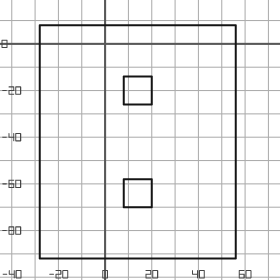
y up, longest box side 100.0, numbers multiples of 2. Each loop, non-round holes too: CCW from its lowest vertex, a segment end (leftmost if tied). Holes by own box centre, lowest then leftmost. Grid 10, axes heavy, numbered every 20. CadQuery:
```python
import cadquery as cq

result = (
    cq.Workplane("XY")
    .moveTo(-28.0, -92.0)
    .lineTo(56.0, -92.0)
    .lineTo(56.0, 8.0)
    .lineTo(-28.0, 8.0)
    .close()
    .moveTo(8.0, -70.0)
    .lineTo(20.0, -70.0)
    .lineTo(20.0, -58.0)
    .lineTo(8.0, -58.0)
    .close()
    .moveTo(8.0, -26.0)
    .lineTo(20.0, -26.0)
    .lineTo(20.0, -14.0)
    .lineTo(8.0, -14.0)
    .close()
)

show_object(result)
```